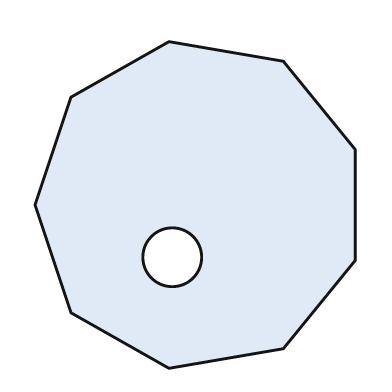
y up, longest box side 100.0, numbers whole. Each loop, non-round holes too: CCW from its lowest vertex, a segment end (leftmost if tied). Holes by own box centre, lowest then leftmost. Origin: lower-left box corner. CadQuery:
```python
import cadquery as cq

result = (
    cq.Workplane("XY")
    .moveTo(41.0, 0.0)
    .lineTo(76.0, 6.0)
    .lineTo(98.0, 33.0)
    .lineTo(98.0, 67.0)
    .lineTo(76.0, 94.0)
    .lineTo(41.0, 100.0)
    .lineTo(11.0, 83.0)
    .lineTo(0.0, 50.0)
    .lineTo(11.0, 17.0)
    .close()
    .moveTo(42.0, 34.0)
    .circle(9.0)
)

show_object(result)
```